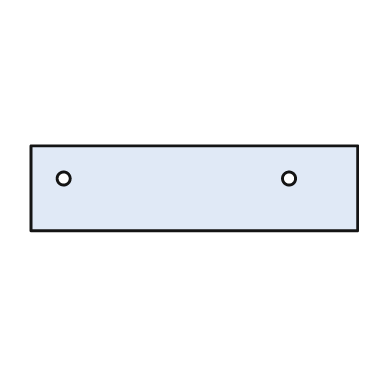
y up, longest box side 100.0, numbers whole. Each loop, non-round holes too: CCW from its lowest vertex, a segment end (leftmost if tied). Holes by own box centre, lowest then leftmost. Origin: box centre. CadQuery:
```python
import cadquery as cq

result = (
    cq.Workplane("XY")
    .moveTo(-50.0, -13.0)
    .lineTo(50.0, -13.0)
    .lineTo(50.0, 13.0)
    .lineTo(-50.0, 13.0)
    .close()
    .moveTo(-40.0, 3.0)
    .circle(2.0)
    .moveTo(29.0, 3.0)
    .circle(2.0)
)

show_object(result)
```